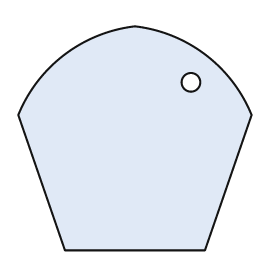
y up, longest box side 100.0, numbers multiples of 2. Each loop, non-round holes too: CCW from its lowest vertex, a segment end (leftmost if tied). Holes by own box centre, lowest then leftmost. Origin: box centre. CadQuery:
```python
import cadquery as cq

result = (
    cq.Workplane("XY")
    .moveTo(-30.0, -48.0)
    .lineTo(30.0, -48.0)
    .lineTo(50.0, 10.0)
    .threePointArc((30.0, 36.0), (0.0, 48.0))
    .threePointArc((-30.0, 36.0), (-50.0, 10.0))
    .close()
    .moveTo(24.0, 24.0)
    .circle(4.0)
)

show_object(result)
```